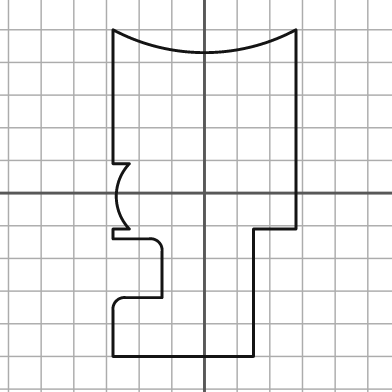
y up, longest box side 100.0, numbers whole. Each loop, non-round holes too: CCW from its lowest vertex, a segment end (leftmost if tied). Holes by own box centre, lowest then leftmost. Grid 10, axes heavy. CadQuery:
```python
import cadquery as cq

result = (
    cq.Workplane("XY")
    .moveTo(-28.0, -50.0)
    .lineTo(15.0, -50.0)
    .lineTo(15.0, -11.0)
    .lineTo(28.0, -11.0)
    .lineTo(28.0, 50.0)
    .threePointArc((0.0, 43.0), (-28.0, 50.0))
    .lineTo(-28.0, 9.0)
    .lineTo(-23.0, 9.0)
    .threePointArc((-27.0, -1.0), (-23.0, -11.0))
    .lineTo(-28.0, -11.0)
    .lineTo(-28.0, -14.0)
    .lineTo(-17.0, -14.0)
    .threePointArc((-14.0, -15.0), (-13.0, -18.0))
    .lineTo(-13.0, -32.0)
    .lineTo(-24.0, -32.0)
    .threePointArc((-27.0, -33.0), (-28.0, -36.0))
    .close()
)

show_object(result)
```